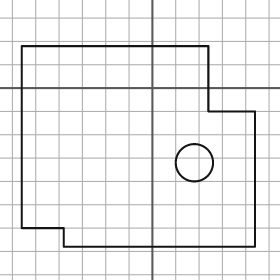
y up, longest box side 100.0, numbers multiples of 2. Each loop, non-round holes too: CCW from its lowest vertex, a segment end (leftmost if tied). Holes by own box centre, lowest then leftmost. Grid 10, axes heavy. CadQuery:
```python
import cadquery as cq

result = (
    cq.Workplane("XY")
    .moveTo(-38.0, -68.0)
    .lineTo(44.0, -68.0)
    .lineTo(44.0, -10.0)
    .lineTo(24.0, -10.0)
    .lineTo(24.0, 18.0)
    .lineTo(-56.0, 18.0)
    .lineTo(-56.0, -60.0)
    .lineTo(-38.0, -60.0)
    .close()
    .moveTo(18.0, -32.0)
    .circle(8.0)
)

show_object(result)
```